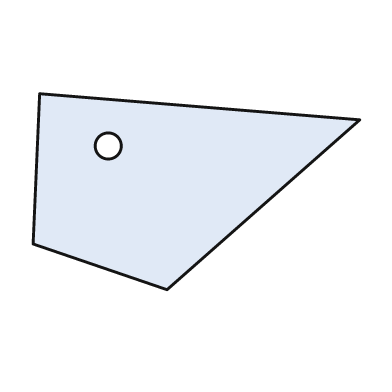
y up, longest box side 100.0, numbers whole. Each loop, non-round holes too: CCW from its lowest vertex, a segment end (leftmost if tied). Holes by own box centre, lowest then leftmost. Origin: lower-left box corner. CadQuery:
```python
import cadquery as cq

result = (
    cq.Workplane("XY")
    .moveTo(41.0, 0.0)
    .lineTo(100.0, 52.0)
    .lineTo(2.0, 60.0)
    .lineTo(0.0, 14.0)
    .close()
    .moveTo(23.0, 44.0)
    .circle(4.0)
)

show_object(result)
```